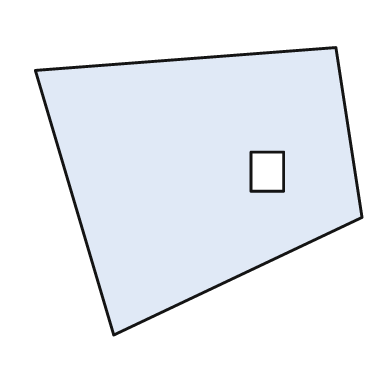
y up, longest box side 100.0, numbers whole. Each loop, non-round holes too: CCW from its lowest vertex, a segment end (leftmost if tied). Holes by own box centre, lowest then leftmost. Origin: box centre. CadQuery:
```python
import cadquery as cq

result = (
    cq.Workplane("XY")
    .moveTo(-26.0, -44.0)
    .lineTo(50.0, -8.0)
    .lineTo(42.0, 44.0)
    .lineTo(-50.0, 37.0)
    .close()
    .moveTo(16.0, 0.0)
    .lineTo(26.0, 0.0)
    .lineTo(26.0, 12.0)
    .lineTo(16.0, 12.0)
    .close()
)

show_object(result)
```